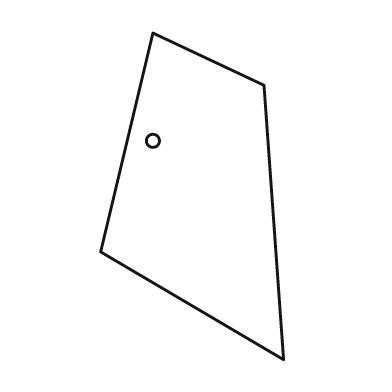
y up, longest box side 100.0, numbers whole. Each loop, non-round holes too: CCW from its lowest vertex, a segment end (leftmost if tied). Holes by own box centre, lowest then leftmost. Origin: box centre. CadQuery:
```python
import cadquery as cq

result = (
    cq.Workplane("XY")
    .moveTo(28.0, -50.0)
    .lineTo(22.0, 34.0)
    .lineTo(-12.0, 50.0)
    .lineTo(-28.0, -17.0)
    .close()
    .moveTo(-12.0, 17.0)
    .circle(2.0)
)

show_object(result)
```